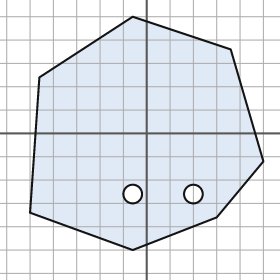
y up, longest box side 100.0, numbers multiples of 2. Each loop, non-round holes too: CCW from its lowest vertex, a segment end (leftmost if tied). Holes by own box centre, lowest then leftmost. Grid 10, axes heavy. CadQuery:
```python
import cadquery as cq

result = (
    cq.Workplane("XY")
    .moveTo(-6.0, -50.0)
    .lineTo(30.0, -36.0)
    .lineTo(50.0, -12.0)
    .lineTo(36.0, 36.0)
    .lineTo(-6.0, 50.0)
    .lineTo(-46.0, 24.0)
    .lineTo(-50.0, -34.0)
    .close()
    .moveTo(-6.0, -26.0)
    .circle(4.0)
    .moveTo(20.0, -26.0)
    .circle(4.0)
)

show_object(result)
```